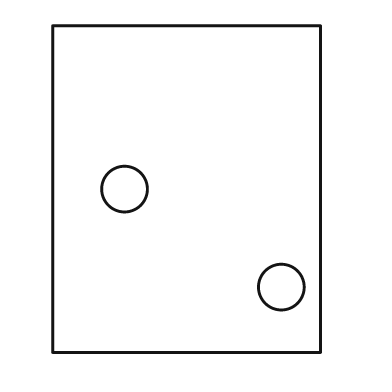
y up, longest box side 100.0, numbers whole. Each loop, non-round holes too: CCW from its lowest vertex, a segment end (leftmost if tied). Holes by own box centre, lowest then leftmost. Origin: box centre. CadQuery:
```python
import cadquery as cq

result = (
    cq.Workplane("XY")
    .moveTo(-41.0, -50.0)
    .lineTo(41.0, -50.0)
    .lineTo(41.0, 50.0)
    .lineTo(-41.0, 50.0)
    .close()
    .moveTo(29.0, -30.0)
    .circle(7.0)
    .moveTo(-19.0, 0.0)
    .circle(7.0)
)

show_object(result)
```